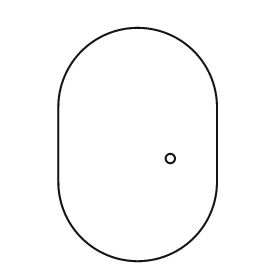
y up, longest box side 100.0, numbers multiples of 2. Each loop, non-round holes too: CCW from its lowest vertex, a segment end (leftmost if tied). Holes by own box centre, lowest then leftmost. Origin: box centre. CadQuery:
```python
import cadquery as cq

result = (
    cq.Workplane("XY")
    .moveTo(-34.0, -16.0)
    .threePointArc((0.0, -50.0), (34.0, -16.0))
    .lineTo(34.0, 16.0)
    .threePointArc((0.0, 50.0), (-34.0, 16.0))
    .close()
    .moveTo(14.0, -6.0)
    .circle(2.0)
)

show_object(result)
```